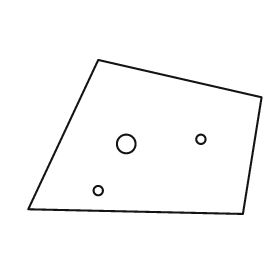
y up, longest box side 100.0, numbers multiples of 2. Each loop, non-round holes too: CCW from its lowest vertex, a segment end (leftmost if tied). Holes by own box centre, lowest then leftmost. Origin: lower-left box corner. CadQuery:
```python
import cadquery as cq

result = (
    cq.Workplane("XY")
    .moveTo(92.0, 0.0)
    .lineTo(100.0, 50.0)
    .lineTo(30.0, 66.0)
    .lineTo(0.0, 2.0)
    .close()
    .moveTo(30.0, 10.0)
    .circle(2.0)
    .moveTo(42.0, 30.0)
    .circle(4.0)
    .moveTo(74.0, 32.0)
    .circle(2.0)
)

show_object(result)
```